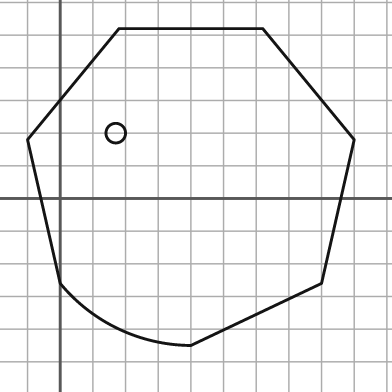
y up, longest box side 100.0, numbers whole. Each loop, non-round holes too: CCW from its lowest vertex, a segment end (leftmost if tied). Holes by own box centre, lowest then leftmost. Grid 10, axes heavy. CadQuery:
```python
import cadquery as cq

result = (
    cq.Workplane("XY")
    .moveTo(40.0, -45.0)
    .lineTo(80.0, -26.0)
    .lineTo(90.0, 18.0)
    .lineTo(62.0, 52.0)
    .lineTo(18.0, 52.0)
    .lineTo(-10.0, 18.0)
    .lineTo(0.0, -26.0)
    .threePointArc((18.0, -40.0), (40.0, -45.0))
    .close()
    .moveTo(17.0, 20.0)
    .circle(3.0)
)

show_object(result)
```